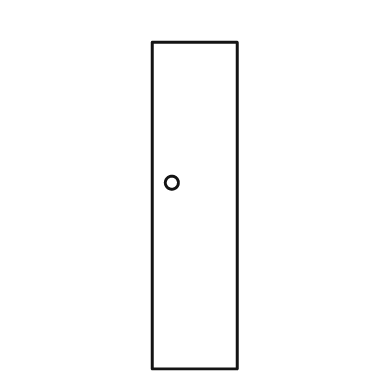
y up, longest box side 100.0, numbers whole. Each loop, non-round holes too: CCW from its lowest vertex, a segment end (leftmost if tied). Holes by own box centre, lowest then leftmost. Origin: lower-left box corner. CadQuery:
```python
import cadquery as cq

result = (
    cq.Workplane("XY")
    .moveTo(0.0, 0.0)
    .lineTo(26.0, 0.0)
    .lineTo(26.0, 100.0)
    .lineTo(0.0, 100.0)
    .close()
    .moveTo(6.0, 57.0)
    .circle(2.0)
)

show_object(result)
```